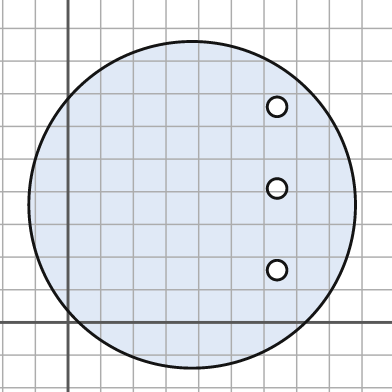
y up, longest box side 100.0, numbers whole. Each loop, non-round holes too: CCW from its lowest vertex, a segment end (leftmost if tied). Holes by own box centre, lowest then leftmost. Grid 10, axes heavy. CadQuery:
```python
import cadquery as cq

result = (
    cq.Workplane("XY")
    .moveTo(38.0, 36.0)
    .circle(50.0)
    .moveTo(64.0, 16.0)
    .circle(3.0)
    .moveTo(64.0, 41.0)
    .circle(3.0)
    .moveTo(64.0, 66.0)
    .circle(3.0)
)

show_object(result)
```